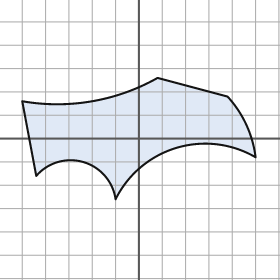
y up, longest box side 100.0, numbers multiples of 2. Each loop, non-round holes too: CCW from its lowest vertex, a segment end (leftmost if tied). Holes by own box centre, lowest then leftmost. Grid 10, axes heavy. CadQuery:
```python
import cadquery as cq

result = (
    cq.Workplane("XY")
    .moveTo(-10.0, -26.0)
    .threePointArc((16.0, -4.0), (50.0, -8.0))
    .threePointArc((46.0, 6.0), (38.0, 18.0))
    .lineTo(8.0, 26.0)
    .threePointArc((-20.0, 16.0), (-50.0, 16.0))
    .lineTo(-44.0, -16.0)
    .threePointArc((-24.0, -10.0), (-10.0, -26.0))
    .close()
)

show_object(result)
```